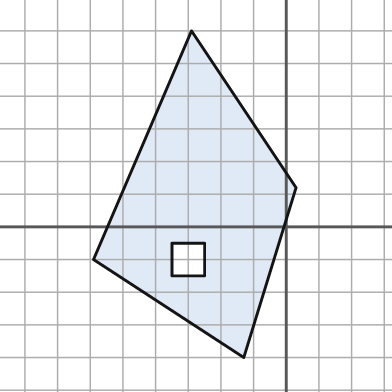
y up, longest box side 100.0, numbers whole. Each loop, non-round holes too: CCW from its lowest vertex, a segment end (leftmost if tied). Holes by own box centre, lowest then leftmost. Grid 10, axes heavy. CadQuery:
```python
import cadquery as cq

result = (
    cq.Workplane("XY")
    .moveTo(-13.0, -40.0)
    .lineTo(3.0, 12.0)
    .lineTo(-29.0, 60.0)
    .lineTo(-59.0, -10.0)
    .close()
    .moveTo(-35.0, -15.0)
    .lineTo(-25.0, -15.0)
    .lineTo(-25.0, -5.0)
    .lineTo(-35.0, -5.0)
    .close()
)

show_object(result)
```